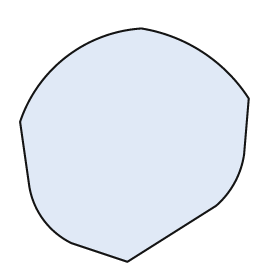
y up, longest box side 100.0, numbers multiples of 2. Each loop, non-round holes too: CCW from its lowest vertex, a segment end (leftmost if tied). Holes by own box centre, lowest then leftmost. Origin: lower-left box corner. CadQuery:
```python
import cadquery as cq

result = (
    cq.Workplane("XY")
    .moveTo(46.0, 0.0)
    .lineTo(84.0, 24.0)
    .threePointArc((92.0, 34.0), (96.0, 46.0))
    .lineTo(98.0, 70.0)
    .threePointArc((78.0, 90.0), (52.0, 100.0))
    .threePointArc((20.0, 88.0), (0.0, 60.0))
    .lineTo(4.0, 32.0)
    .threePointArc((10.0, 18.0), (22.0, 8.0))
    .close()
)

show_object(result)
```